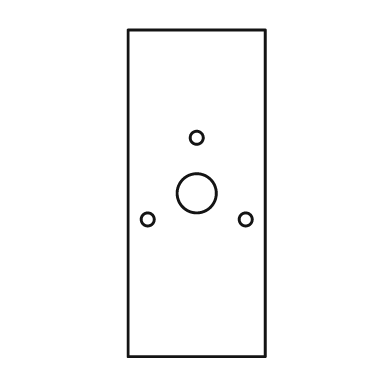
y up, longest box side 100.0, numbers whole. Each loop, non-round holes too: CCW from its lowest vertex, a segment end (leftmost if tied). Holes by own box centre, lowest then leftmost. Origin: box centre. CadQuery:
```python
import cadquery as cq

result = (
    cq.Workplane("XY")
    .moveTo(-21.0, -50.0)
    .lineTo(21.0, -50.0)
    .lineTo(21.0, 50.0)
    .lineTo(-21.0, 50.0)
    .close()
    .moveTo(-15.0, -8.0)
    .circle(2.0)
    .moveTo(15.0, -8.0)
    .circle(2.0)
    .moveTo(0.0, 0.0)
    .circle(6.0)
    .moveTo(0.0, 17.0)
    .circle(2.0)
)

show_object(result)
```